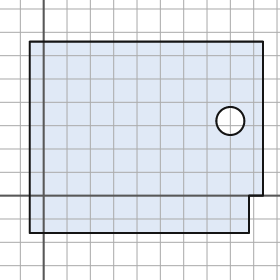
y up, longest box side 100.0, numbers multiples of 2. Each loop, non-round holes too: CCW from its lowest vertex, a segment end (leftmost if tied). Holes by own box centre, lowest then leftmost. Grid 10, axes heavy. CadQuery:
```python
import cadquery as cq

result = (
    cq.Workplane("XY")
    .moveTo(-6.0, -16.0)
    .lineTo(88.0, -16.0)
    .lineTo(88.0, 0.0)
    .lineTo(94.0, 0.0)
    .lineTo(94.0, 66.0)
    .lineTo(-6.0, 66.0)
    .close()
    .moveTo(80.0, 32.0)
    .circle(6.0)
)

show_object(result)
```